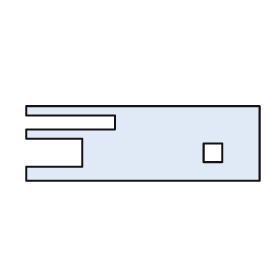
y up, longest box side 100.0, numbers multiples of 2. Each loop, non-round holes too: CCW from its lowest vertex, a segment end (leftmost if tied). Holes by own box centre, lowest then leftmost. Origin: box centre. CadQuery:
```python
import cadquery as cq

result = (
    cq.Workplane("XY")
    .moveTo(-50.0, -16.0)
    .lineTo(50.0, -16.0)
    .lineTo(50.0, 16.0)
    .lineTo(-50.0, 16.0)
    .lineTo(-50.0, 12.0)
    .lineTo(-12.0, 12.0)
    .lineTo(-12.0, 6.0)
    .lineTo(-50.0, 6.0)
    .lineTo(-50.0, 2.0)
    .lineTo(-26.0, 2.0)
    .lineTo(-26.0, -10.0)
    .lineTo(-50.0, -10.0)
    .close()
    .moveTo(26.0, -8.0)
    .lineTo(34.0, -8.0)
    .lineTo(34.0, 0.0)
    .lineTo(26.0, 0.0)
    .close()
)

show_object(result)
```